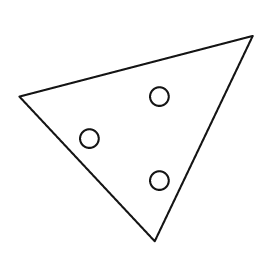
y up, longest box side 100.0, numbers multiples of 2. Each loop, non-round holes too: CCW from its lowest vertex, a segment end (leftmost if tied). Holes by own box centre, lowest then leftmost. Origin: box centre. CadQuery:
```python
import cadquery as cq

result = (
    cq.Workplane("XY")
    .moveTo(8.0, -44.0)
    .lineTo(50.0, 44.0)
    .lineTo(-50.0, 18.0)
    .close()
    .moveTo(10.0, -18.0)
    .circle(4.0)
    .moveTo(-20.0, 0.0)
    .circle(4.0)
    .moveTo(10.0, 18.0)
    .circle(4.0)
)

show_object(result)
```